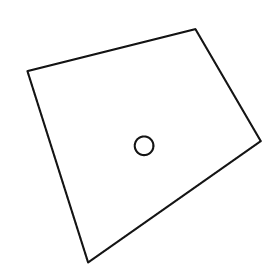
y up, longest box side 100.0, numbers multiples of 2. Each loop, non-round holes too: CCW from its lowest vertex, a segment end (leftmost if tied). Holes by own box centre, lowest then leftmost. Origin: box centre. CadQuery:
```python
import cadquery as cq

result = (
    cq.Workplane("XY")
    .moveTo(-24.0, -50.0)
    .lineTo(50.0, 2.0)
    .lineTo(22.0, 50.0)
    .lineTo(-50.0, 32.0)
    .close()
    .moveTo(0.0, 0.0)
    .circle(4.0)
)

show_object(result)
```